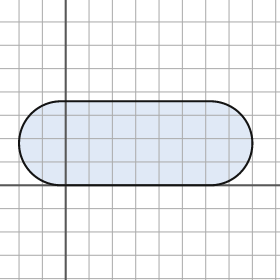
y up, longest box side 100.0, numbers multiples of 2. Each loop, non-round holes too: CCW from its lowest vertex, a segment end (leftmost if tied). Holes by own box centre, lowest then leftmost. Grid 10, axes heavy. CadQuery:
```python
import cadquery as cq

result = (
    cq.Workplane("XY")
    .moveTo(-2.0, 0.0)
    .lineTo(62.0, 0.0)
    .threePointArc((80.0, 18.0), (62.0, 36.0))
    .lineTo(-2.0, 36.0)
    .threePointArc((-20.0, 18.0), (-2.0, 0.0))
    .close()
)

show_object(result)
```